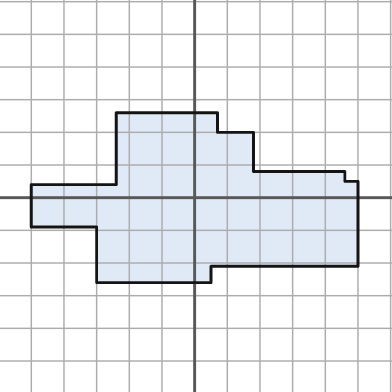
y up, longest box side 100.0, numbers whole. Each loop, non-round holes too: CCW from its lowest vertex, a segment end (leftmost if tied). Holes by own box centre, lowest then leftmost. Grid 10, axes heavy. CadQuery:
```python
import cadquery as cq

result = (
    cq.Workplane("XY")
    .moveTo(-30.0, -26.0)
    .lineTo(5.0, -26.0)
    .lineTo(5.0, -21.0)
    .lineTo(50.0, -21.0)
    .lineTo(50.0, 5.0)
    .lineTo(46.0, 5.0)
    .lineTo(46.0, 8.0)
    .lineTo(18.0, 8.0)
    .lineTo(18.0, 20.0)
    .lineTo(7.0, 20.0)
    .lineTo(7.0, 26.0)
    .lineTo(-24.0, 26.0)
    .lineTo(-24.0, 4.0)
    .lineTo(-50.0, 4.0)
    .lineTo(-50.0, -9.0)
    .lineTo(-30.0, -9.0)
    .close()
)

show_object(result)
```